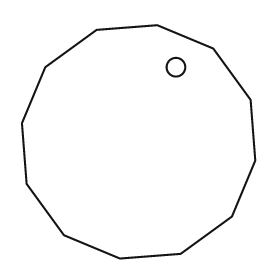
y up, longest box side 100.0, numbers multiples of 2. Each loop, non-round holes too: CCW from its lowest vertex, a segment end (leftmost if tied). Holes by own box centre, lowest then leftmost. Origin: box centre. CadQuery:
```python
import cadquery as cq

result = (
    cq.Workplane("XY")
    .moveTo(-8.0, -50.0)
    .lineTo(18.0, -48.0)
    .lineTo(40.0, -32.0)
    .lineTo(50.0, -8.0)
    .lineTo(48.0, 18.0)
    .lineTo(32.0, 40.0)
    .lineTo(8.0, 50.0)
    .lineTo(-18.0, 48.0)
    .lineTo(-40.0, 32.0)
    .lineTo(-50.0, 8.0)
    .lineTo(-48.0, -18.0)
    .lineTo(-32.0, -40.0)
    .close()
    .moveTo(16.0, 32.0)
    .circle(4.0)
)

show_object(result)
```